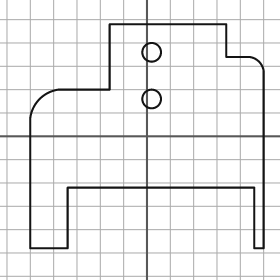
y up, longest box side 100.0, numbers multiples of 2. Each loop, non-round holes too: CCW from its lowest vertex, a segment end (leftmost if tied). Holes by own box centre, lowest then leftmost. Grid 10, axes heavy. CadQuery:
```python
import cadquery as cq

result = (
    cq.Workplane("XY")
    .moveTo(-50.0, -48.0)
    .lineTo(-34.0, -48.0)
    .lineTo(-34.0, -22.0)
    .lineTo(46.0, -22.0)
    .lineTo(46.0, -48.0)
    .lineTo(50.0, -48.0)
    .lineTo(50.0, 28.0)
    .threePointArc((48.0, 32.0), (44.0, 34.0))
    .lineTo(34.0, 34.0)
    .lineTo(34.0, 48.0)
    .lineTo(-16.0, 48.0)
    .lineTo(-16.0, 20.0)
    .lineTo(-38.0, 20.0)
    .threePointArc((-46.0, 16.0), (-50.0, 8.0))
    .close()
    .moveTo(2.0, 16.0)
    .circle(4.0)
    .moveTo(2.0, 36.0)
    .circle(4.0)
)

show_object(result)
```